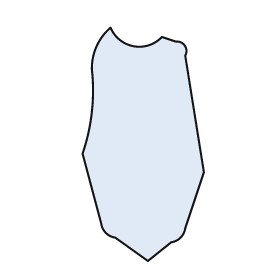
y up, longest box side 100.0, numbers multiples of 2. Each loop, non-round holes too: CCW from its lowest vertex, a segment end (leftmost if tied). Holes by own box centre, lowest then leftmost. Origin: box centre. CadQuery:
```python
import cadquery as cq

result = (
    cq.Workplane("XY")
    .moveTo(2.0, -50.0)
    .lineTo(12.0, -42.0)
    .threePointArc((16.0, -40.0), (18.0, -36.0))
    .lineTo(26.0, -12.0)
    .lineTo(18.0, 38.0)
    .threePointArc((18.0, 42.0), (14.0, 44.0))
    .lineTo(8.0, 46.0)
    .threePointArc((-4.0, 42.0), (-14.0, 50.0))
    .threePointArc((-20.0, 42.0), (-22.0, 32.0))
    .threePointArc((-22.0, 14.0), (-26.0, -4.0))
    .lineTo(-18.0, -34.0)
    .threePointArc((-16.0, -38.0), (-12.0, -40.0))
    .close()
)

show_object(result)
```